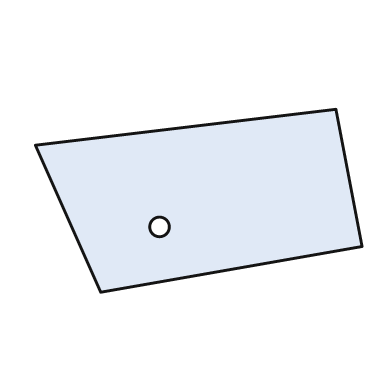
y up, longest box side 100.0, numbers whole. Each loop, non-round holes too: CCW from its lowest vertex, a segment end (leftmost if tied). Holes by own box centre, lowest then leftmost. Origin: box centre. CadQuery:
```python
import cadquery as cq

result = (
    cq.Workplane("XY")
    .moveTo(-30.0, -28.0)
    .lineTo(50.0, -14.0)
    .lineTo(42.0, 28.0)
    .lineTo(-50.0, 17.0)
    .close()
    .moveTo(-12.0, -8.0)
    .circle(3.0)
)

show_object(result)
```